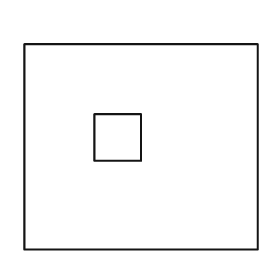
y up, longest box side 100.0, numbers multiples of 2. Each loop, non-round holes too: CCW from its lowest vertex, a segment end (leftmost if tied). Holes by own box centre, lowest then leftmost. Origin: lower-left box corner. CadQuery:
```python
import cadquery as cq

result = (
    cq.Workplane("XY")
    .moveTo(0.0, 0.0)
    .lineTo(100.0, 0.0)
    .lineTo(100.0, 88.0)
    .lineTo(0.0, 88.0)
    .close()
    .moveTo(30.0, 38.0)
    .lineTo(50.0, 38.0)
    .lineTo(50.0, 58.0)
    .lineTo(30.0, 58.0)
    .close()
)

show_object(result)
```